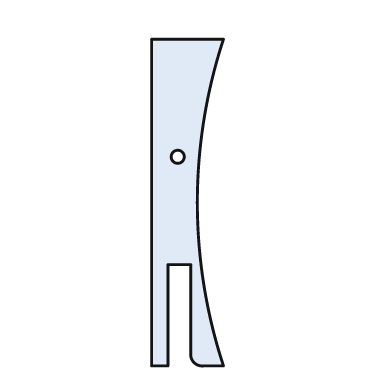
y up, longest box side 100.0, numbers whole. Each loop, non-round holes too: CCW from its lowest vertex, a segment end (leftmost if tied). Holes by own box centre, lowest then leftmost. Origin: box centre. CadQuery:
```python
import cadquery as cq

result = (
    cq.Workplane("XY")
    .moveTo(-11.0, -50.0)
    .lineTo(-6.0, -50.0)
    .lineTo(-6.0, -19.0)
    .lineTo(1.0, -19.0)
    .lineTo(1.0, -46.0)
    .threePointArc((2.0, -49.0), (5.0, -50.0))
    .lineTo(11.0, -50.0)
    .threePointArc((3.0, 0.0), (11.0, 50.0))
    .lineTo(-11.0, 50.0)
    .close()
    .moveTo(-3.0, 14.0)
    .circle(2.0)
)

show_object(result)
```